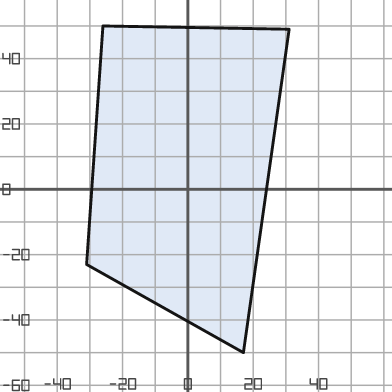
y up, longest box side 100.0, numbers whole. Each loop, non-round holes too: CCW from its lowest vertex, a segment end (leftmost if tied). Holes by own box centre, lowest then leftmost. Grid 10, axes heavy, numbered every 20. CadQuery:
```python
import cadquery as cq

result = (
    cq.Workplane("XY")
    .moveTo(17.0, -50.0)
    .lineTo(31.0, 49.0)
    .lineTo(-26.0, 50.0)
    .lineTo(-31.0, -23.0)
    .close()
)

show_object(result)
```